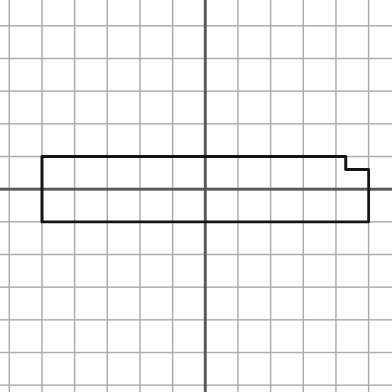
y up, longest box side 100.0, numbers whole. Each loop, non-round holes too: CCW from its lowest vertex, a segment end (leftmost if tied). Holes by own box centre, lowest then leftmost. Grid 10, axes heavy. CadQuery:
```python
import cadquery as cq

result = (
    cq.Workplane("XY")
    .moveTo(-50.0, -10.0)
    .lineTo(50.0, -10.0)
    .lineTo(50.0, 6.0)
    .lineTo(43.0, 6.0)
    .lineTo(43.0, 10.0)
    .lineTo(-50.0, 10.0)
    .close()
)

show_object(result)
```